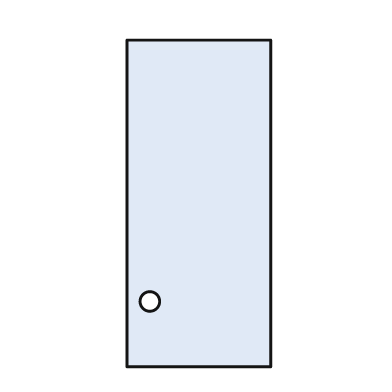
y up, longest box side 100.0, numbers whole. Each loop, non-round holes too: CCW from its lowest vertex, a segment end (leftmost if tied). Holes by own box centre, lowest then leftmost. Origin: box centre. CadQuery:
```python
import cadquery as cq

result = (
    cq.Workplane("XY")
    .moveTo(-22.0, -50.0)
    .lineTo(22.0, -50.0)
    .lineTo(22.0, 50.0)
    .lineTo(-22.0, 50.0)
    .close()
    .moveTo(-15.0, -30.0)
    .circle(3.0)
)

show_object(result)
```